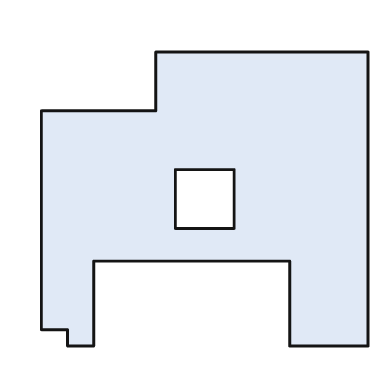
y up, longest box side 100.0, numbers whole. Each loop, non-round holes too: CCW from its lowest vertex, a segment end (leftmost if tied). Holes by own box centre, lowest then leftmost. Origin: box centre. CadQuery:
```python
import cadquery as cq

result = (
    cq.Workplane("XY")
    .moveTo(-42.0, -45.0)
    .lineTo(-34.0, -45.0)
    .lineTo(-34.0, -19.0)
    .lineTo(26.0, -19.0)
    .lineTo(26.0, -45.0)
    .lineTo(50.0, -45.0)
    .lineTo(50.0, 45.0)
    .lineTo(-15.0, 45.0)
    .lineTo(-15.0, 27.0)
    .lineTo(-50.0, 27.0)
    .lineTo(-50.0, -40.0)
    .lineTo(-42.0, -40.0)
    .close()
    .moveTo(-9.0, -9.0)
    .lineTo(9.0, -9.0)
    .lineTo(9.0, 9.0)
    .lineTo(-9.0, 9.0)
    .close()
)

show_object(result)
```